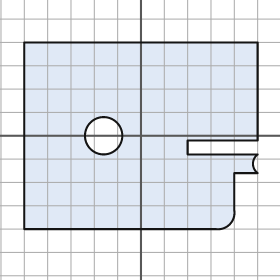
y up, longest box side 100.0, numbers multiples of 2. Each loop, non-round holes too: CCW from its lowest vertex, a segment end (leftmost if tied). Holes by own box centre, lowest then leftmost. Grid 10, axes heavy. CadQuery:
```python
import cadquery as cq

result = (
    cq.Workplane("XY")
    .moveTo(-50.0, -40.0)
    .lineTo(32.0, -40.0)
    .threePointArc((38.0, -38.0), (40.0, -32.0))
    .lineTo(40.0, -16.0)
    .lineTo(50.0, -16.0)
    .threePointArc((48.0, -12.0), (50.0, -8.0))
    .lineTo(20.0, -8.0)
    .lineTo(20.0, -2.0)
    .lineTo(50.0, -2.0)
    .lineTo(50.0, 40.0)
    .lineTo(-50.0, 40.0)
    .close()
    .moveTo(-16.0, 0.0)
    .circle(8.0)
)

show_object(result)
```